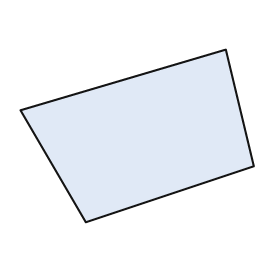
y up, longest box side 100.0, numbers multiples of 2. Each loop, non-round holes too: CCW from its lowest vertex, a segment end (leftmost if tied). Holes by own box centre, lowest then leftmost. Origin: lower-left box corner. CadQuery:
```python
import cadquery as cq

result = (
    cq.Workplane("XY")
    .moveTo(28.0, 0.0)
    .lineTo(100.0, 24.0)
    .lineTo(88.0, 74.0)
    .lineTo(0.0, 48.0)
    .close()
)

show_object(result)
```